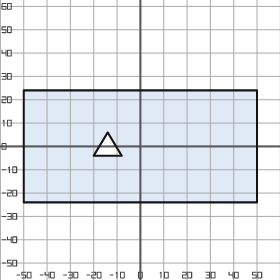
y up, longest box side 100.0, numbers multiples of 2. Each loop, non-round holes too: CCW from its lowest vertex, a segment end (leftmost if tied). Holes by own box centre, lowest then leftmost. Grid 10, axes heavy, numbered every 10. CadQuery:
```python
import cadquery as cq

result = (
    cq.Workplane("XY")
    .moveTo(-50.0, -24.0)
    .lineTo(50.0, -24.0)
    .lineTo(50.0, 24.0)
    .lineTo(-50.0, 24.0)
    .close()
    .moveTo(-20.0, -4.0)
    .lineTo(-8.0, -4.0)
    .lineTo(-14.0, 6.0)
    .close()
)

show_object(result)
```